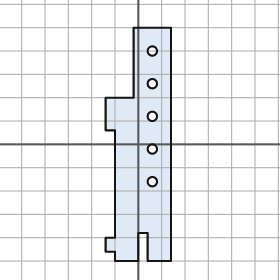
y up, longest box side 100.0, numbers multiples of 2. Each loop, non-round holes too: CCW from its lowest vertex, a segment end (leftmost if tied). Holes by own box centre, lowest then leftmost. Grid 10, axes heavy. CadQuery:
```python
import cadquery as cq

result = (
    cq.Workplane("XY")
    .moveTo(-10.0, -50.0)
    .lineTo(0.0, -50.0)
    .lineTo(0.0, -38.0)
    .lineTo(4.0, -38.0)
    .lineTo(4.0, -50.0)
    .lineTo(14.0, -50.0)
    .lineTo(14.0, 50.0)
    .lineTo(-2.0, 50.0)
    .lineTo(-2.0, 20.0)
    .lineTo(-14.0, 20.0)
    .lineTo(-14.0, 6.0)
    .lineTo(-10.0, 6.0)
    .lineTo(-10.0, -40.0)
    .lineTo(-14.0, -40.0)
    .lineTo(-14.0, -46.0)
    .lineTo(-10.0, -46.0)
    .close()
    .moveTo(6.0, -16.0)
    .circle(2.0)
    .moveTo(6.0, -2.0)
    .circle(2.0)
    .moveTo(6.0, 12.0)
    .circle(2.0)
    .moveTo(6.0, 26.0)
    .circle(2.0)
    .moveTo(6.0, 40.0)
    .circle(2.0)
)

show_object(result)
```